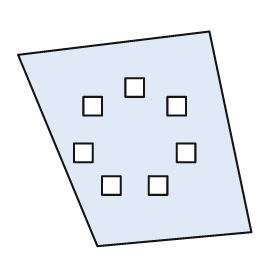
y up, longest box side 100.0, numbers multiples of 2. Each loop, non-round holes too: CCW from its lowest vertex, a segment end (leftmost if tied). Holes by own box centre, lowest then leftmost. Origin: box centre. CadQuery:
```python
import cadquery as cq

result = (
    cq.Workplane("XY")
    .moveTo(-16.0, -46.0)
    .lineTo(50.0, -40.0)
    .lineTo(32.0, 46.0)
    .lineTo(-50.0, 36.0)
    .close()
    .moveTo(-14.0, -24.0)
    .lineTo(-6.0, -24.0)
    .lineTo(-6.0, -16.0)
    .lineTo(-14.0, -16.0)
    .close()
    .moveTo(6.0, -24.0)
    .lineTo(14.0, -24.0)
    .lineTo(14.0, -16.0)
    .lineTo(6.0, -16.0)
    .close()
    .moveTo(-26.0, -10.0)
    .lineTo(-18.0, -10.0)
    .lineTo(-18.0, -2.0)
    .lineTo(-26.0, -2.0)
    .close()
    .moveTo(18.0, -10.0)
    .lineTo(26.0, -10.0)
    .lineTo(26.0, -2.0)
    .lineTo(18.0, -2.0)
    .close()
    .moveTo(-22.0, 10.0)
    .lineTo(-14.0, 10.0)
    .lineTo(-14.0, 18.0)
    .lineTo(-22.0, 18.0)
    .close()
    .moveTo(14.0, 10.0)
    .lineTo(22.0, 10.0)
    .lineTo(22.0, 18.0)
    .lineTo(14.0, 18.0)
    .close()
    .moveTo(-4.0, 18.0)
    .lineTo(4.0, 18.0)
    .lineTo(4.0, 26.0)
    .lineTo(-4.0, 26.0)
    .close()
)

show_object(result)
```